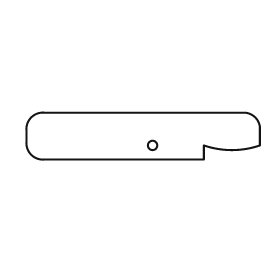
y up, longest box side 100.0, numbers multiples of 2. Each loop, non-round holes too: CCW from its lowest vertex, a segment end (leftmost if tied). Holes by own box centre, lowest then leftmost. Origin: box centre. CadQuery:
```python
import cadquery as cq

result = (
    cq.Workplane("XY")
    .moveTo(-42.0, -10.0)
    .lineTo(26.0, -10.0)
    .lineTo(26.0, -4.0)
    .threePointArc((38.0, -6.0), (50.0, -4.0))
    .lineTo(50.0, 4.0)
    .threePointArc((48.0, 8.0), (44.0, 10.0))
    .lineTo(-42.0, 10.0)
    .threePointArc((-48.0, 8.0), (-50.0, 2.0))
    .lineTo(-50.0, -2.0)
    .threePointArc((-48.0, -8.0), (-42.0, -10.0))
    .close()
    .moveTo(4.0, -4.0)
    .circle(2.0)
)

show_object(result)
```